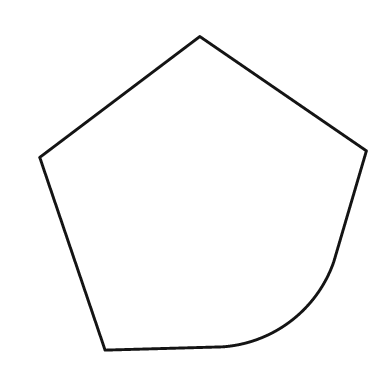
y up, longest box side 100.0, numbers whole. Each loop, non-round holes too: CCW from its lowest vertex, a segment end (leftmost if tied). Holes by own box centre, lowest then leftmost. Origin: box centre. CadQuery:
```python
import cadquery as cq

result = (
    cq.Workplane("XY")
    .moveTo(-30.0, -48.0)
    .lineTo(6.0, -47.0)
    .threePointArc((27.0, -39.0), (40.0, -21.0))
    .lineTo(50.0, 13.0)
    .lineTo(-1.0, 48.0)
    .lineTo(-50.0, 11.0)
    .close()
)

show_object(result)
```